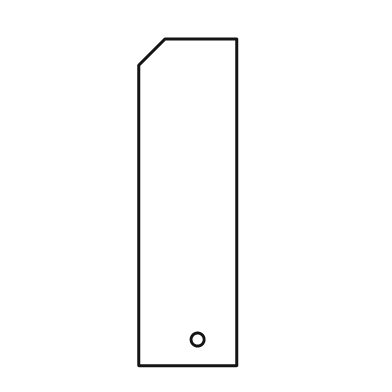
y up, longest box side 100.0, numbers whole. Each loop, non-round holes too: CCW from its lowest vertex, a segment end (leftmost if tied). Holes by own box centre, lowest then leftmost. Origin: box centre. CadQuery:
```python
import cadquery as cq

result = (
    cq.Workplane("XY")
    .moveTo(-15.0, -50.0)
    .lineTo(15.0, -50.0)
    .lineTo(15.0, 50.0)
    .lineTo(-7.0, 50.0)
    .lineTo(-15.0, 42.0)
    .close()
    .moveTo(3.0, -42.0)
    .circle(2.0)
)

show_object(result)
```